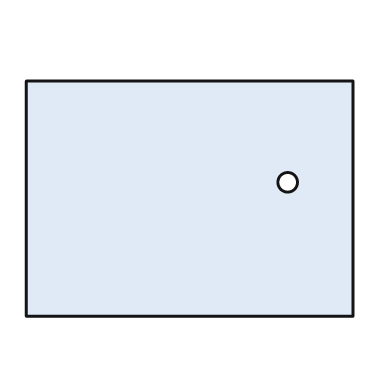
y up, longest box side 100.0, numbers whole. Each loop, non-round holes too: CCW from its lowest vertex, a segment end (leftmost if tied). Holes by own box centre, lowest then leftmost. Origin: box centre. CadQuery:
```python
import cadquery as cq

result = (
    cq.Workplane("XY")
    .moveTo(-50.0, -36.0)
    .lineTo(50.0, -36.0)
    .lineTo(50.0, 36.0)
    .lineTo(-50.0, 36.0)
    .close()
    .moveTo(30.0, 5.0)
    .circle(3.0)
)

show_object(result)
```